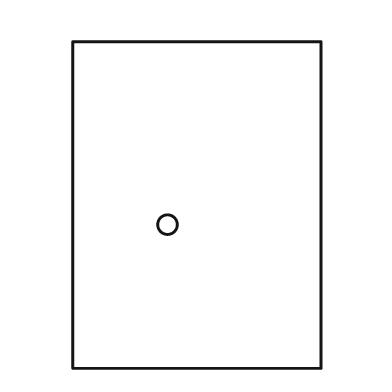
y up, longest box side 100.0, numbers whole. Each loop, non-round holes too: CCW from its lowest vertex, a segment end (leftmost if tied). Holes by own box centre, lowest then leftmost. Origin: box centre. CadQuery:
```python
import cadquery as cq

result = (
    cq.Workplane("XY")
    .moveTo(-38.0, -50.0)
    .lineTo(38.0, -50.0)
    .lineTo(38.0, 50.0)
    .lineTo(-38.0, 50.0)
    .close()
    .moveTo(-9.0, -6.0)
    .circle(3.0)
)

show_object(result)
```